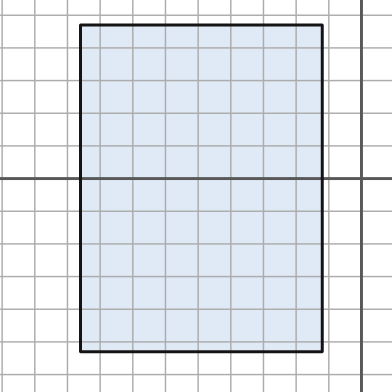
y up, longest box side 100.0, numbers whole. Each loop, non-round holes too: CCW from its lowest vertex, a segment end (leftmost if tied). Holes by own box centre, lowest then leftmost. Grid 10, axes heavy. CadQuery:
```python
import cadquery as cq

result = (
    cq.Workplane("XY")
    .moveTo(-86.0, -53.0)
    .lineTo(-12.0, -53.0)
    .lineTo(-12.0, 47.0)
    .lineTo(-86.0, 47.0)
    .close()
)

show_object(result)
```